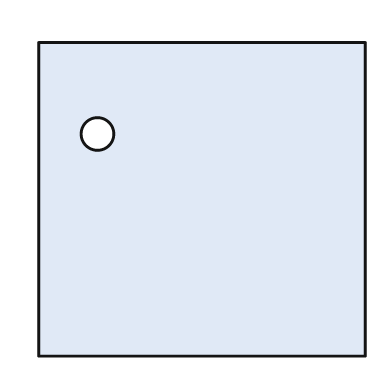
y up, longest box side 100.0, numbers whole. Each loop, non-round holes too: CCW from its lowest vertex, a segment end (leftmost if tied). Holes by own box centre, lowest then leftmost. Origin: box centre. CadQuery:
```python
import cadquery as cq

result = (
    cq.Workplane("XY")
    .moveTo(-50.0, -48.0)
    .lineTo(50.0, -48.0)
    .lineTo(50.0, 48.0)
    .lineTo(-50.0, 48.0)
    .close()
    .moveTo(-32.0, 20.0)
    .circle(5.0)
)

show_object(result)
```